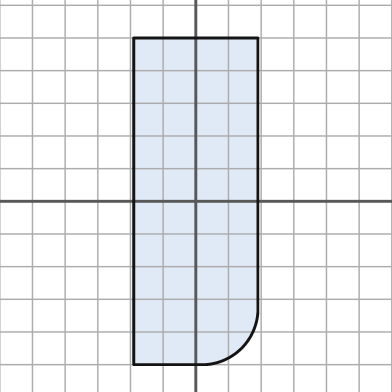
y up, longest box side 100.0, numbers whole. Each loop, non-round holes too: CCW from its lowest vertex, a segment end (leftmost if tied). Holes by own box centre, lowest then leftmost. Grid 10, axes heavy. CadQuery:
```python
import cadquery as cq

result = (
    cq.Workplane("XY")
    .moveTo(-19.0, -50.0)
    .lineTo(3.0, -50.0)
    .threePointArc((14.0, -45.0), (19.0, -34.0))
    .lineTo(19.0, 50.0)
    .lineTo(-19.0, 50.0)
    .close()
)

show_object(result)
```